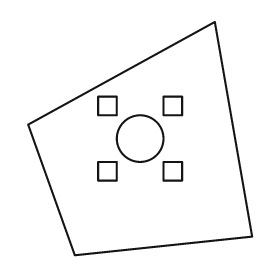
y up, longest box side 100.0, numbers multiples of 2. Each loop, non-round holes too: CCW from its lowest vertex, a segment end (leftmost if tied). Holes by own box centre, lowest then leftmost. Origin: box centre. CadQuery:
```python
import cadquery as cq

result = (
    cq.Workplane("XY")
    .moveTo(-28.0, -50.0)
    .lineTo(48.0, -42.0)
    .lineTo(32.0, 50.0)
    .lineTo(-48.0, 6.0)
    .close()
    .moveTo(-18.0, -18.0)
    .lineTo(-10.0, -18.0)
    .lineTo(-10.0, -10.0)
    .lineTo(-18.0, -10.0)
    .close()
    .moveTo(10.0, -18.0)
    .lineTo(18.0, -18.0)
    .lineTo(18.0, -10.0)
    .lineTo(10.0, -10.0)
    .close()
    .moveTo(0.0, 0.0)
    .circle(10.0)
    .moveTo(-18.0, 10.0)
    .lineTo(-10.0, 10.0)
    .lineTo(-10.0, 18.0)
    .lineTo(-18.0, 18.0)
    .close()
    .moveTo(10.0, 10.0)
    .lineTo(18.0, 10.0)
    .lineTo(18.0, 18.0)
    .lineTo(10.0, 18.0)
    .close()
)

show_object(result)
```